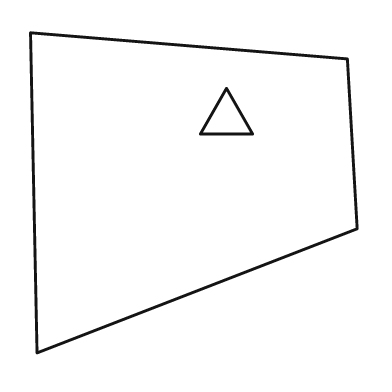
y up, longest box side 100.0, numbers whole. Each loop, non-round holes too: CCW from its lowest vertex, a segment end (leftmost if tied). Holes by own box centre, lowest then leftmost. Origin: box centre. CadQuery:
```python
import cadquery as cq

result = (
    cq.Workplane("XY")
    .moveTo(-48.0, -49.0)
    .lineTo(50.0, -11.0)
    .lineTo(47.0, 41.0)
    .lineTo(-50.0, 49.0)
    .close()
    .moveTo(2.0, 18.0)
    .lineTo(18.0, 18.0)
    .lineTo(10.0, 32.0)
    .close()
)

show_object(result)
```